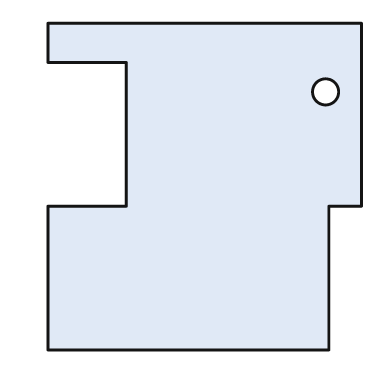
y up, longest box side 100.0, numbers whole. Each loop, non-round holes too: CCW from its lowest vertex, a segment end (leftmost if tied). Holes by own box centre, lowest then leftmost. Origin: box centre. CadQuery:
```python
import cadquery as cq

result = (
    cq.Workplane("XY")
    .moveTo(-48.0, -50.0)
    .lineTo(38.0, -50.0)
    .lineTo(38.0, -6.0)
    .lineTo(48.0, -6.0)
    .lineTo(48.0, 50.0)
    .lineTo(-48.0, 50.0)
    .lineTo(-48.0, 38.0)
    .lineTo(-24.0, 38.0)
    .lineTo(-24.0, -6.0)
    .lineTo(-48.0, -6.0)
    .close()
    .moveTo(37.0, 29.0)
    .circle(4.0)
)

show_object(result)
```